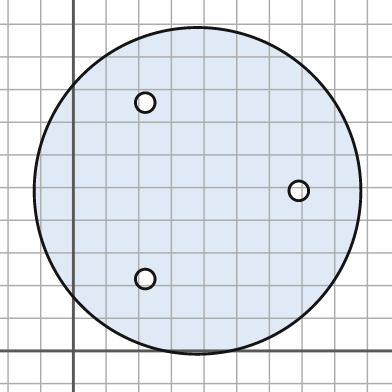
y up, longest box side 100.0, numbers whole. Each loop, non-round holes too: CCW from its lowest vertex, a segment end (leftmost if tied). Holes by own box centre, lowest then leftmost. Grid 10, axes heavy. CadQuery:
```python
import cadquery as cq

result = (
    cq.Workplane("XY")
    .moveTo(38.0, 49.0)
    .circle(50.0)
    .moveTo(22.0, 22.0)
    .circle(3.0)
    .moveTo(69.0, 49.0)
    .circle(3.0)
    .moveTo(22.0, 76.0)
    .circle(3.0)
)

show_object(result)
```